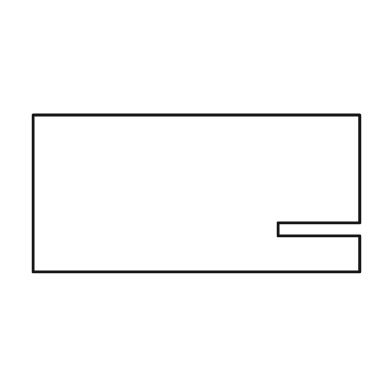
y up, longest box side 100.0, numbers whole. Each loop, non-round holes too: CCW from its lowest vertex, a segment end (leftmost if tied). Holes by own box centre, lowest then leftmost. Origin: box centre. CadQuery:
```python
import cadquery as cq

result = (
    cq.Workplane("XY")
    .moveTo(-50.0, -24.0)
    .lineTo(50.0, -24.0)
    .lineTo(50.0, -13.0)
    .lineTo(25.0, -13.0)
    .lineTo(25.0, -9.0)
    .lineTo(50.0, -9.0)
    .lineTo(50.0, 24.0)
    .lineTo(-50.0, 24.0)
    .close()
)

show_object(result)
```